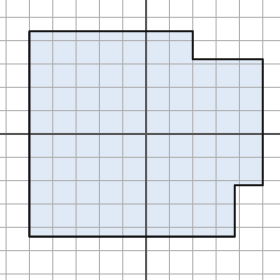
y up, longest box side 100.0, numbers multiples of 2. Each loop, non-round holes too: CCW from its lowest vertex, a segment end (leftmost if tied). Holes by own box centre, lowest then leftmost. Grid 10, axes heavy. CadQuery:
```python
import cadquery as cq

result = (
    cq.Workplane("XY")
    .moveTo(-50.0, -44.0)
    .lineTo(38.0, -44.0)
    .lineTo(38.0, -22.0)
    .lineTo(50.0, -22.0)
    .lineTo(50.0, 32.0)
    .lineTo(20.0, 32.0)
    .lineTo(20.0, 44.0)
    .lineTo(-50.0, 44.0)
    .close()
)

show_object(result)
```